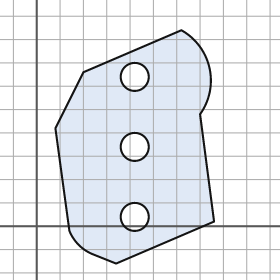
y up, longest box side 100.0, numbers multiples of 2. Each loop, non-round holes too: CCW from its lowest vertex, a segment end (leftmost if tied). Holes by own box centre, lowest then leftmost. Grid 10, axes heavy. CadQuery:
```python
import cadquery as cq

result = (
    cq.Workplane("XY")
    .moveTo(34.0, -16.0)
    .lineTo(76.0, 2.0)
    .lineTo(70.0, 48.0)
    .threePointArc((74.0, 68.0), (62.0, 84.0))
    .lineTo(20.0, 66.0)
    .lineTo(8.0, 42.0)
    .lineTo(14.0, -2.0)
    .threePointArc((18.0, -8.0), (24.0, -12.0))
    .close()
    .moveTo(42.0, 4.0)
    .circle(6.0)
    .moveTo(42.0, 34.0)
    .circle(6.0)
    .moveTo(42.0, 64.0)
    .circle(6.0)
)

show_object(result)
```